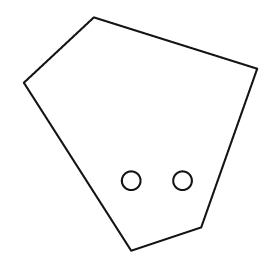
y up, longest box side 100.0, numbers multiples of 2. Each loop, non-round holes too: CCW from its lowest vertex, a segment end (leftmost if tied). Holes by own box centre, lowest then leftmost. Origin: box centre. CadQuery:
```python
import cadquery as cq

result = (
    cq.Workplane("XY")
    .moveTo(-4.0, -50.0)
    .lineTo(26.0, -40.0)
    .lineTo(50.0, 28.0)
    .lineTo(-20.0, 50.0)
    .lineTo(-50.0, 22.0)
    .close()
    .moveTo(-4.0, -20.0)
    .circle(4.0)
    .moveTo(18.0, -20.0)
    .circle(4.0)
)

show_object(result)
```